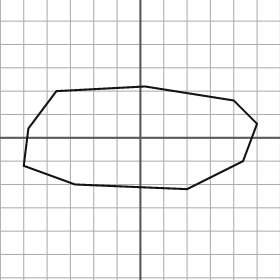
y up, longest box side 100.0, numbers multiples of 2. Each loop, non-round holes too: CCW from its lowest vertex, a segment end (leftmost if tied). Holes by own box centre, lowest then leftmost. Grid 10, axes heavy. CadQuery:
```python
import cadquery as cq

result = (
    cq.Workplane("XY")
    .moveTo(20.0, -22.0)
    .lineTo(44.0, -10.0)
    .lineTo(50.0, 6.0)
    .lineTo(40.0, 16.0)
    .lineTo(2.0, 22.0)
    .lineTo(-36.0, 20.0)
    .lineTo(-48.0, 4.0)
    .lineTo(-50.0, -12.0)
    .lineTo(-28.0, -20.0)
    .close()
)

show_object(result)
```